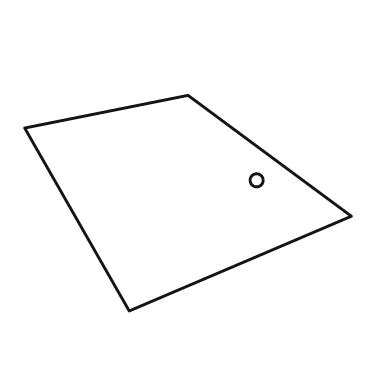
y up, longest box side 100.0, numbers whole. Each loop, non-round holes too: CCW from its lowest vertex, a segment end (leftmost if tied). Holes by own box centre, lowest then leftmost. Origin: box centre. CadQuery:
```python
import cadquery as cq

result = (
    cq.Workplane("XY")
    .moveTo(-18.0, -33.0)
    .lineTo(50.0, -4.0)
    .lineTo(0.0, 33.0)
    .lineTo(-50.0, 23.0)
    .close()
    .moveTo(21.0, 7.0)
    .circle(2.0)
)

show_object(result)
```